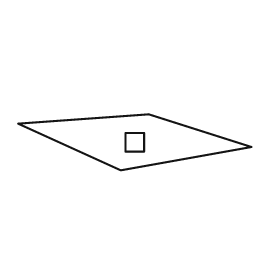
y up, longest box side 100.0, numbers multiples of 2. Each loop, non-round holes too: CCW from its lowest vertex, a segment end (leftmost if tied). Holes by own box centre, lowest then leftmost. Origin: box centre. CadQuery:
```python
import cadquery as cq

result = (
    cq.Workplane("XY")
    .moveTo(-6.0, -12.0)
    .lineTo(50.0, -2.0)
    .lineTo(6.0, 12.0)
    .lineTo(-50.0, 8.0)
    .close()
    .moveTo(-4.0, -4.0)
    .lineTo(4.0, -4.0)
    .lineTo(4.0, 4.0)
    .lineTo(-4.0, 4.0)
    .close()
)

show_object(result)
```